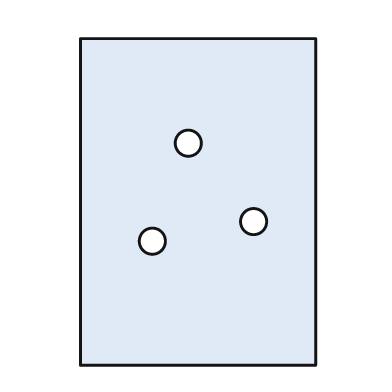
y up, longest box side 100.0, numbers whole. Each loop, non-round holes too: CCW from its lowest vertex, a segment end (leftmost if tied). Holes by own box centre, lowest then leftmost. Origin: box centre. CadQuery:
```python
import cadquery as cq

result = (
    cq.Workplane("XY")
    .moveTo(-36.0, -50.0)
    .lineTo(36.0, -50.0)
    .lineTo(36.0, 50.0)
    .lineTo(-36.0, 50.0)
    .close()
    .moveTo(-14.0, -12.0)
    .circle(4.0)
    .moveTo(17.0, -6.0)
    .circle(4.0)
    .moveTo(-3.0, 18.0)
    .circle(4.0)
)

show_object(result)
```